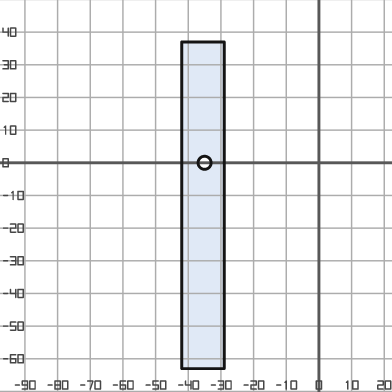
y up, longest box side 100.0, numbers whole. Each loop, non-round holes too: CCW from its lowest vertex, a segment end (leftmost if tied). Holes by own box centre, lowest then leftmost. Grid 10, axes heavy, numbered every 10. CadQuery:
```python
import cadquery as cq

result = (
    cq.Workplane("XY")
    .moveTo(-42.0, -63.0)
    .lineTo(-29.0, -63.0)
    .lineTo(-29.0, 37.0)
    .lineTo(-42.0, 37.0)
    .close()
    .moveTo(-35.0, 0.0)
    .circle(2.0)
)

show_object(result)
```